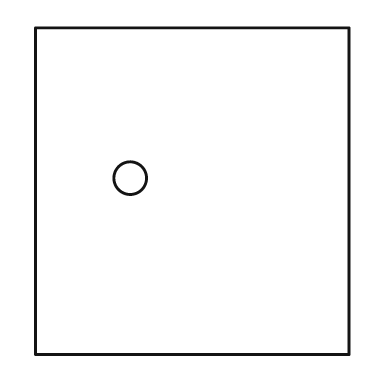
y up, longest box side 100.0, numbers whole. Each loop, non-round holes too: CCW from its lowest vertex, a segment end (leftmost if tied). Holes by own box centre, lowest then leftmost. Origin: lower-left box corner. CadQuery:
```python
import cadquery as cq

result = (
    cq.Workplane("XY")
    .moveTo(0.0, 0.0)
    .lineTo(96.0, 0.0)
    .lineTo(96.0, 100.0)
    .lineTo(0.0, 100.0)
    .close()
    .moveTo(29.0, 54.0)
    .circle(5.0)
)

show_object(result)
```